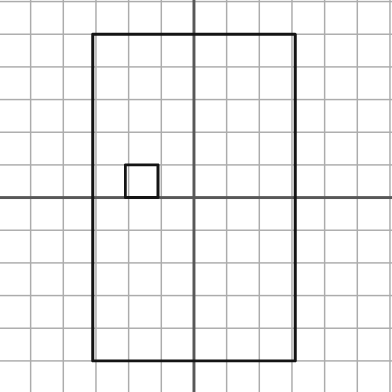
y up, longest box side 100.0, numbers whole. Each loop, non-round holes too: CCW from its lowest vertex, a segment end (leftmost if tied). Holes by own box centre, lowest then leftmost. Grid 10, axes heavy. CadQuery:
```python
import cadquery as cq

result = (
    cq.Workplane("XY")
    .moveTo(-31.0, -50.0)
    .lineTo(31.0, -50.0)
    .lineTo(31.0, 50.0)
    .lineTo(-31.0, 50.0)
    .close()
    .moveTo(-21.0, 0.0)
    .lineTo(-11.0, 0.0)
    .lineTo(-11.0, 10.0)
    .lineTo(-21.0, 10.0)
    .close()
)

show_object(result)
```